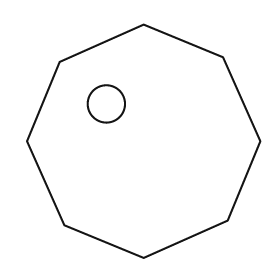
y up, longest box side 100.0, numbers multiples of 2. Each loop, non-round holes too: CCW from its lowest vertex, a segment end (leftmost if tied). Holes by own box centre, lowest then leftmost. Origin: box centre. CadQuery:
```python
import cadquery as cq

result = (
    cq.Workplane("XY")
    .moveTo(0.0, -50.0)
    .lineTo(36.0, -34.0)
    .lineTo(50.0, 0.0)
    .lineTo(34.0, 36.0)
    .lineTo(0.0, 50.0)
    .lineTo(-36.0, 34.0)
    .lineTo(-50.0, 0.0)
    .lineTo(-34.0, -36.0)
    .close()
    .moveTo(-16.0, 16.0)
    .circle(8.0)
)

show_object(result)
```